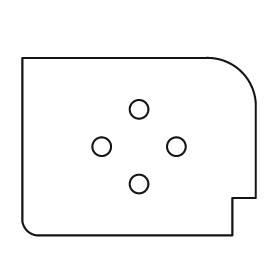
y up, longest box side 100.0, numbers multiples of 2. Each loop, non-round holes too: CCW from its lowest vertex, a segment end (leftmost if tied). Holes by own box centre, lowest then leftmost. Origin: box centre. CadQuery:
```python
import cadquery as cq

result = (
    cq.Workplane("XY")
    .moveTo(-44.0, -38.0)
    .lineTo(40.0, -38.0)
    .lineTo(40.0, -22.0)
    .lineTo(50.0, -22.0)
    .lineTo(50.0, 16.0)
    .threePointArc((44.0, 32.0), (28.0, 38.0))
    .lineTo(-50.0, 38.0)
    .lineTo(-50.0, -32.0)
    .threePointArc((-48.0, -36.0), (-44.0, -38.0))
    .close()
    .moveTo(0.0, -16.0)
    .circle(4.0)
    .moveTo(-16.0, 0.0)
    .circle(4.0)
    .moveTo(16.0, 0.0)
    .circle(4.0)
    .moveTo(0.0, 16.0)
    .circle(4.0)
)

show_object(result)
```